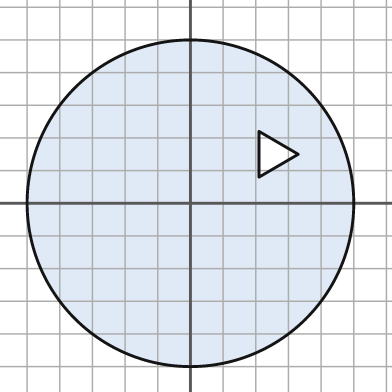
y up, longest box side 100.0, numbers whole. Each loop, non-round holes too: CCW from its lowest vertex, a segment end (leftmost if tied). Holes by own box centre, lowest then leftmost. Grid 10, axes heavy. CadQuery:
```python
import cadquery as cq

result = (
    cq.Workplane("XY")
    .moveTo(0.0, 0.0)
    .circle(50.0)
    .moveTo(21.0, 8.0)
    .lineTo(33.0, 15.0)
    .lineTo(21.0, 22.0)
    .close()
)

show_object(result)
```